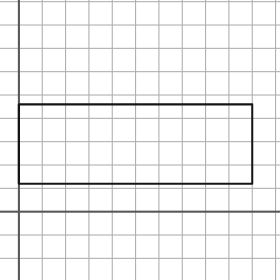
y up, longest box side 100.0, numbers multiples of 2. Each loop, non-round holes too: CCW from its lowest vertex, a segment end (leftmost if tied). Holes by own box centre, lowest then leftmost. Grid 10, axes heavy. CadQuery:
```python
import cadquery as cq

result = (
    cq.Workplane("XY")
    .moveTo(0.0, 12.0)
    .lineTo(100.0, 12.0)
    .lineTo(100.0, 46.0)
    .lineTo(0.0, 46.0)
    .close()
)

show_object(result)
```